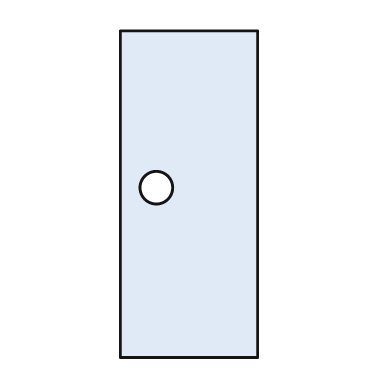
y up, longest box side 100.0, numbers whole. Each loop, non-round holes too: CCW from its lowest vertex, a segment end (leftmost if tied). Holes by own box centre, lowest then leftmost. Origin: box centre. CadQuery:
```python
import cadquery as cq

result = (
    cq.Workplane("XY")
    .moveTo(-21.0, -50.0)
    .lineTo(21.0, -50.0)
    .lineTo(21.0, 50.0)
    .lineTo(-21.0, 50.0)
    .close()
    .moveTo(-10.0, 2.0)
    .circle(5.0)
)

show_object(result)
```